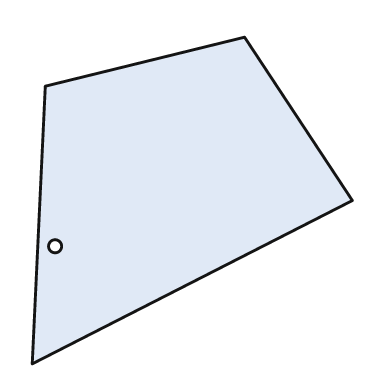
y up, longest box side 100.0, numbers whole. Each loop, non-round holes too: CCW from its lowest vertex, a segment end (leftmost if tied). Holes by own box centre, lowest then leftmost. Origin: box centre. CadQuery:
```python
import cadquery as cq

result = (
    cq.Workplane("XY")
    .moveTo(-49.0, -50.0)
    .lineTo(49.0, 0.0)
    .lineTo(16.0, 50.0)
    .lineTo(-45.0, 35.0)
    .close()
    .moveTo(-42.0, -14.0)
    .circle(2.0)
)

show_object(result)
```